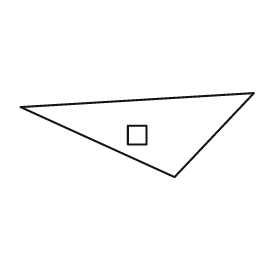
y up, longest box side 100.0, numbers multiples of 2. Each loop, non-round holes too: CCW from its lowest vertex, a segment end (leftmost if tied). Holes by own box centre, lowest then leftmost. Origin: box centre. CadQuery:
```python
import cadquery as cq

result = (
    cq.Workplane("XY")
    .moveTo(16.0, -18.0)
    .lineTo(50.0, 18.0)
    .lineTo(-50.0, 12.0)
    .close()
    .moveTo(-4.0, -4.0)
    .lineTo(4.0, -4.0)
    .lineTo(4.0, 4.0)
    .lineTo(-4.0, 4.0)
    .close()
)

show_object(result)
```